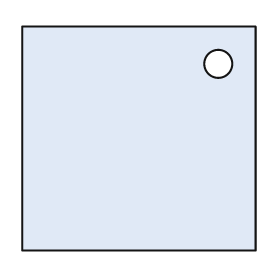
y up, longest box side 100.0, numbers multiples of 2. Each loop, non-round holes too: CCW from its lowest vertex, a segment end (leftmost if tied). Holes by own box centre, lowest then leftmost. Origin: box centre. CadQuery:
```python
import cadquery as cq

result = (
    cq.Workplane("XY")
    .moveTo(-50.0, -48.0)
    .lineTo(50.0, -48.0)
    .lineTo(50.0, 48.0)
    .lineTo(-50.0, 48.0)
    .close()
    .moveTo(34.0, 32.0)
    .circle(6.0)
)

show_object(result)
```